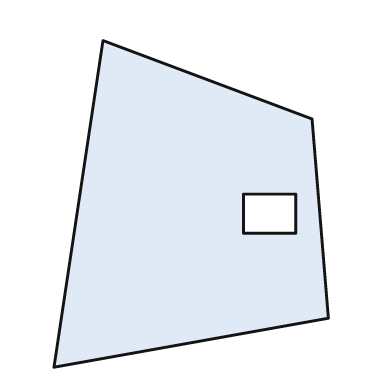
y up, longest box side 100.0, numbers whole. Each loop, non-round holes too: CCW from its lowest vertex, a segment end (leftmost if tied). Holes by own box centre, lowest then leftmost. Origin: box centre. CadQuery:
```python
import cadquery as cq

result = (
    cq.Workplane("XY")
    .moveTo(-42.0, -50.0)
    .lineTo(42.0, -35.0)
    .lineTo(37.0, 26.0)
    .lineTo(-27.0, 50.0)
    .close()
    .moveTo(16.0, -9.0)
    .lineTo(32.0, -9.0)
    .lineTo(32.0, 3.0)
    .lineTo(16.0, 3.0)
    .close()
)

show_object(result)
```